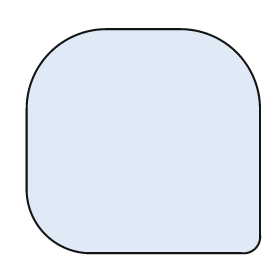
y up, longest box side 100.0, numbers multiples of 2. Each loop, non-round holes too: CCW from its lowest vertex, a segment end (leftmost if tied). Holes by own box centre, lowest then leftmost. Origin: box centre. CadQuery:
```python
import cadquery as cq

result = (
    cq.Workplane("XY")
    .moveTo(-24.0, -48.0)
    .lineTo(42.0, -48.0)
    .threePointArc((48.0, -46.0), (50.0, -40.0))
    .lineTo(50.0, 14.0)
    .threePointArc((40.0, 38.0), (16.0, 48.0))
    .lineTo(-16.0, 48.0)
    .threePointArc((-40.0, 38.0), (-50.0, 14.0))
    .lineTo(-50.0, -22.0)
    .threePointArc((-42.0, -40.0), (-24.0, -48.0))
    .close()
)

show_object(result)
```